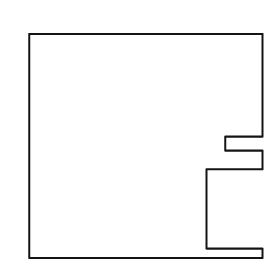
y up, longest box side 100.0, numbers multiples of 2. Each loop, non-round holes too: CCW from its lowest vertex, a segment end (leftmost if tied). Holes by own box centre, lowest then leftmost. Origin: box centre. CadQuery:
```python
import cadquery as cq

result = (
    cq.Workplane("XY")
    .moveTo(-50.0, -48.0)
    .lineTo(50.0, -48.0)
    .lineTo(50.0, -44.0)
    .lineTo(26.0, -44.0)
    .lineTo(26.0, -10.0)
    .lineTo(50.0, -10.0)
    .lineTo(50.0, -2.0)
    .lineTo(34.0, -2.0)
    .lineTo(34.0, 4.0)
    .lineTo(50.0, 4.0)
    .lineTo(50.0, 48.0)
    .lineTo(-50.0, 48.0)
    .close()
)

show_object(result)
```